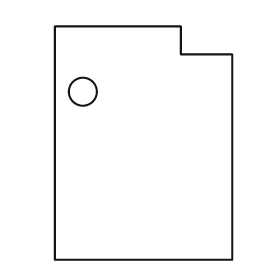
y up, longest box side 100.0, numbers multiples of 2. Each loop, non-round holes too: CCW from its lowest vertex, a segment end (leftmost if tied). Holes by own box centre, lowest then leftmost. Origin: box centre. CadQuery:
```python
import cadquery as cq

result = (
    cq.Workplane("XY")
    .moveTo(-38.0, -50.0)
    .lineTo(38.0, -50.0)
    .lineTo(38.0, 38.0)
    .lineTo(16.0, 38.0)
    .lineTo(16.0, 50.0)
    .lineTo(-38.0, 50.0)
    .close()
    .moveTo(-26.0, 22.0)
    .circle(6.0)
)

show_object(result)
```